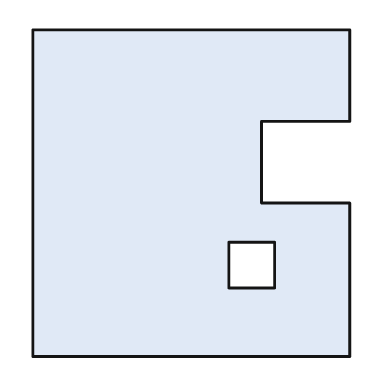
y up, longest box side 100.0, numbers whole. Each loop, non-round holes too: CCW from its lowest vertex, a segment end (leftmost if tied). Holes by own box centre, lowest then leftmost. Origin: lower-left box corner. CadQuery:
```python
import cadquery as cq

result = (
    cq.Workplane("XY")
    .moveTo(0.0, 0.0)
    .lineTo(97.0, 0.0)
    .lineTo(97.0, 47.0)
    .lineTo(70.0, 47.0)
    .lineTo(70.0, 72.0)
    .lineTo(97.0, 72.0)
    .lineTo(97.0, 100.0)
    .lineTo(0.0, 100.0)
    .close()
    .moveTo(60.0, 21.0)
    .lineTo(74.0, 21.0)
    .lineTo(74.0, 35.0)
    .lineTo(60.0, 35.0)
    .close()
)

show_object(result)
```